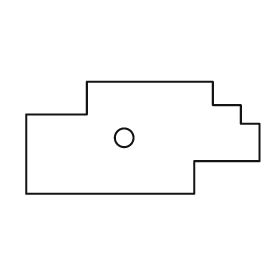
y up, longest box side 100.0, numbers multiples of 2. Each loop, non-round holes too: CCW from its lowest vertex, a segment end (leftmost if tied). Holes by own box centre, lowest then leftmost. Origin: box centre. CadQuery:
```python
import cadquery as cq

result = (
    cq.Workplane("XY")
    .moveTo(-50.0, -24.0)
    .lineTo(22.0, -24.0)
    .lineTo(22.0, -10.0)
    .lineTo(50.0, -10.0)
    .lineTo(50.0, 6.0)
    .lineTo(42.0, 6.0)
    .lineTo(42.0, 14.0)
    .lineTo(30.0, 14.0)
    .lineTo(30.0, 24.0)
    .lineTo(-24.0, 24.0)
    .lineTo(-24.0, 10.0)
    .lineTo(-50.0, 10.0)
    .close()
    .moveTo(-8.0, 0.0)
    .circle(4.0)
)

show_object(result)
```